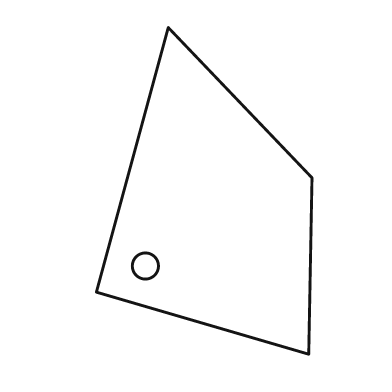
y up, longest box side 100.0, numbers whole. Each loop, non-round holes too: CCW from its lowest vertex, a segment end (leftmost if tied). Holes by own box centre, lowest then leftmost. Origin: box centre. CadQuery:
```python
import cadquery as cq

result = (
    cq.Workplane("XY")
    .moveTo(32.0, -50.0)
    .lineTo(33.0, 4.0)
    .lineTo(-11.0, 50.0)
    .lineTo(-33.0, -31.0)
    .close()
    .moveTo(-18.0, -23.0)
    .circle(4.0)
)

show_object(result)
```